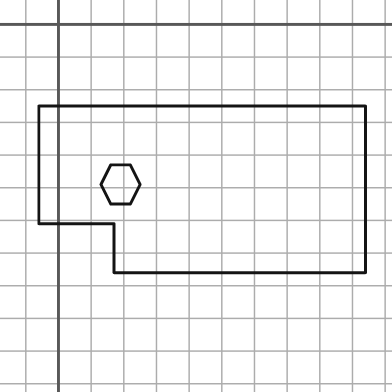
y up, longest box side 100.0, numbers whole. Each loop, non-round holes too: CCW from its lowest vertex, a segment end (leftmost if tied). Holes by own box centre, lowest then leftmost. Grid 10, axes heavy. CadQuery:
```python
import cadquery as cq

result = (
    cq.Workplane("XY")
    .moveTo(17.0, -76.0)
    .lineTo(94.0, -76.0)
    .lineTo(94.0, -25.0)
    .lineTo(-6.0, -25.0)
    .lineTo(-6.0, -61.0)
    .lineTo(17.0, -61.0)
    .close()
    .moveTo(16.0, -55.0)
    .lineTo(22.0, -55.0)
    .lineTo(25.0, -49.0)
    .lineTo(22.0, -43.0)
    .lineTo(16.0, -43.0)
    .lineTo(13.0, -49.0)
    .close()
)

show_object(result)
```